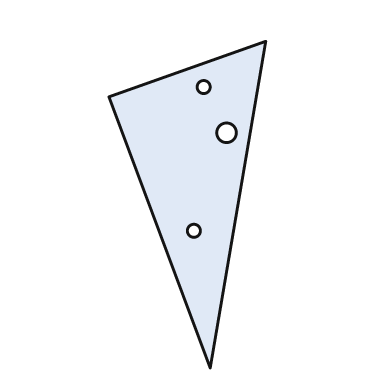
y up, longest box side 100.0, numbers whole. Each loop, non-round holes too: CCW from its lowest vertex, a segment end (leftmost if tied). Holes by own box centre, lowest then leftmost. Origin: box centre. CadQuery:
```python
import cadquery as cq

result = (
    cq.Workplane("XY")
    .moveTo(7.0, -50.0)
    .lineTo(24.0, 50.0)
    .lineTo(-24.0, 33.0)
    .close()
    .moveTo(2.0, -8.0)
    .circle(2.0)
    .moveTo(12.0, 22.0)
    .circle(3.0)
    .moveTo(5.0, 36.0)
    .circle(2.0)
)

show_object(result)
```